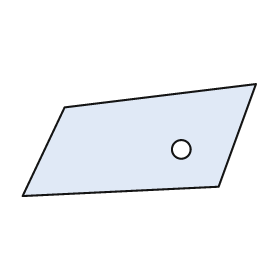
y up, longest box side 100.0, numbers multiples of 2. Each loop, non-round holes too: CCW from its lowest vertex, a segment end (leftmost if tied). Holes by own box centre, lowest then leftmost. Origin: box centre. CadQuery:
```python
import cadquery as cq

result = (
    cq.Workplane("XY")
    .moveTo(-50.0, -24.0)
    .lineTo(34.0, -20.0)
    .lineTo(50.0, 24.0)
    .lineTo(-32.0, 14.0)
    .close()
    .moveTo(18.0, -4.0)
    .circle(4.0)
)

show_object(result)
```